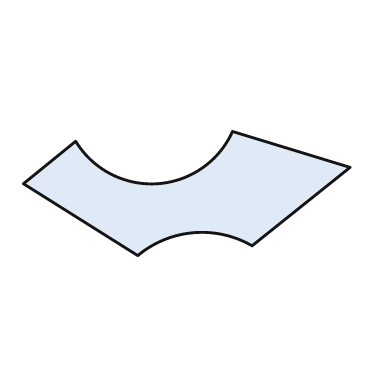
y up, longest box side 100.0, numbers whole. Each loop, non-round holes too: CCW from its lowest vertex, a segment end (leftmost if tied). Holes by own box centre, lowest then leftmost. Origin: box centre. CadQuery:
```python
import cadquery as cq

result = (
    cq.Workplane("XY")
    .moveTo(-15.0, -19.0)
    .threePointArc((2.0, -12.0), (20.0, -16.0))
    .lineTo(50.0, 8.0)
    .lineTo(14.0, 19.0)
    .threePointArc((-9.0, 3.0), (-34.0, 16.0))
    .lineTo(-50.0, 3.0)
    .close()
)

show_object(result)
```